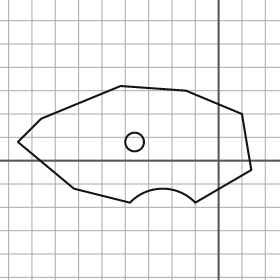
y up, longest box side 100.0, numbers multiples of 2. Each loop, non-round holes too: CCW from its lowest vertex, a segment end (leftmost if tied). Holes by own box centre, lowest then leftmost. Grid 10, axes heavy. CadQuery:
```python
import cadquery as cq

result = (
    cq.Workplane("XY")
    .moveTo(-38.0, -18.0)
    .threePointArc((-24.0, -12.0), (-10.0, -18.0))
    .lineTo(14.0, -4.0)
    .lineTo(10.0, 20.0)
    .lineTo(-14.0, 30.0)
    .lineTo(-42.0, 32.0)
    .lineTo(-76.0, 18.0)
    .lineTo(-86.0, 8.0)
    .lineTo(-62.0, -12.0)
    .close()
    .moveTo(-36.0, 8.0)
    .circle(4.0)
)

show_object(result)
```